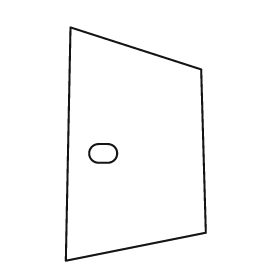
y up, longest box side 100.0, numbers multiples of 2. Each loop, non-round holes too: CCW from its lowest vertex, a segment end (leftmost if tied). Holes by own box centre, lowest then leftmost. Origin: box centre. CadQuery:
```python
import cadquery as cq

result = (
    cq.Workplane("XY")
    .moveTo(-30.0, -50.0)
    .lineTo(30.0, -38.0)
    .lineTo(28.0, 32.0)
    .lineTo(-28.0, 50.0)
    .close()
    .moveTo(-16.0, -8.0)
    .lineTo(-12.0, -8.0)
    .threePointArc((-8.0, -4.0), (-12.0, 0.0))
    .lineTo(-16.0, 0.0)
    .threePointArc((-20.0, -4.0), (-16.0, -8.0))
    .close()
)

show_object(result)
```